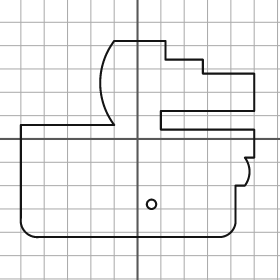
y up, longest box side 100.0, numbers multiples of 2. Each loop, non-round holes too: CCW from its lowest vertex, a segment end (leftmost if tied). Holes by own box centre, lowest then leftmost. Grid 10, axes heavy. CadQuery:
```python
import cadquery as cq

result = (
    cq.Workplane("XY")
    .moveTo(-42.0, -42.0)
    .lineTo(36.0, -42.0)
    .threePointArc((40.0, -40.0), (42.0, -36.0))
    .lineTo(42.0, -20.0)
    .lineTo(46.0, -20.0)
    .threePointArc((48.0, -14.0), (46.0, -8.0))
    .lineTo(50.0, -8.0)
    .lineTo(50.0, 4.0)
    .lineTo(10.0, 4.0)
    .lineTo(10.0, 12.0)
    .lineTo(50.0, 12.0)
    .lineTo(50.0, 28.0)
    .lineTo(28.0, 28.0)
    .lineTo(28.0, 34.0)
    .lineTo(12.0, 34.0)
    .lineTo(12.0, 42.0)
    .lineTo(-10.0, 42.0)
    .threePointArc((-16.0, 24.0), (-10.0, 6.0))
    .lineTo(-50.0, 6.0)
    .lineTo(-50.0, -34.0)
    .threePointArc((-48.0, -40.0), (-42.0, -42.0))
    .close()
    .moveTo(6.0, -28.0)
    .circle(2.0)
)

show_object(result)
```